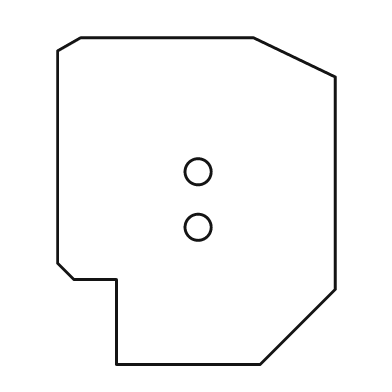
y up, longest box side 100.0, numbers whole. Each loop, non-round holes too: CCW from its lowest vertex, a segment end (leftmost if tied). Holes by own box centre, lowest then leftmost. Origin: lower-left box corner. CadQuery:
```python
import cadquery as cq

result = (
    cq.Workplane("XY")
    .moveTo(18.0, 0.0)
    .lineTo(62.0, 0.0)
    .lineTo(85.0, 23.0)
    .lineTo(85.0, 88.0)
    .lineTo(60.0, 100.0)
    .lineTo(7.0, 100.0)
    .lineTo(0.0, 96.0)
    .lineTo(0.0, 31.0)
    .lineTo(5.0, 26.0)
    .lineTo(18.0, 26.0)
    .close()
    .moveTo(43.0, 42.0)
    .circle(4.0)
    .moveTo(43.0, 59.0)
    .circle(4.0)
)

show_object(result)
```